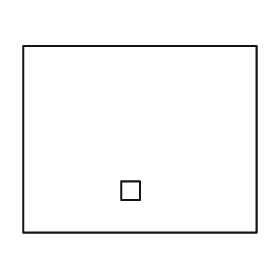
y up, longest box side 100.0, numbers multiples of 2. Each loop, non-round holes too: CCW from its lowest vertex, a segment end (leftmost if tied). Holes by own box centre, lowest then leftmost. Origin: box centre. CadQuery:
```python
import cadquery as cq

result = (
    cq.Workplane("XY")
    .moveTo(-50.0, -40.0)
    .lineTo(50.0, -40.0)
    .lineTo(50.0, 40.0)
    .lineTo(-50.0, 40.0)
    .close()
    .moveTo(-8.0, -26.0)
    .lineTo(0.0, -26.0)
    .lineTo(0.0, -18.0)
    .lineTo(-8.0, -18.0)
    .close()
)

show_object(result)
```